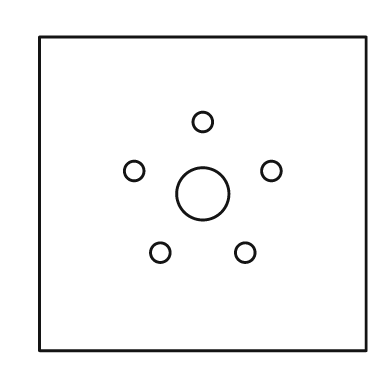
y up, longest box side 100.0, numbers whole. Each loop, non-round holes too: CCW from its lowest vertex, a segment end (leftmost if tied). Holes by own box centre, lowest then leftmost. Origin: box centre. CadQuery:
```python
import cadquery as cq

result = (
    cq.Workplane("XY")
    .moveTo(-50.0, -48.0)
    .lineTo(50.0, -48.0)
    .lineTo(50.0, 48.0)
    .lineTo(-50.0, 48.0)
    .close()
    .moveTo(-13.0, -18.0)
    .circle(3.0)
    .moveTo(13.0, -18.0)
    .circle(3.0)
    .moveTo(0.0, 0.0)
    .circle(8.0)
    .moveTo(-21.0, 7.0)
    .circle(3.0)
    .moveTo(21.0, 7.0)
    .circle(3.0)
    .moveTo(0.0, 22.0)
    .circle(3.0)
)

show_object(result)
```